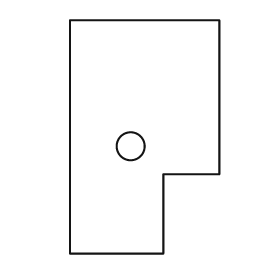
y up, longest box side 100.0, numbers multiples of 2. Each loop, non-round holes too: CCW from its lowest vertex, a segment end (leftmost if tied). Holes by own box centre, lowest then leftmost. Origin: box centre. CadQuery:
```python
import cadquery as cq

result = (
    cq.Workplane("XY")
    .moveTo(-32.0, -50.0)
    .lineTo(8.0, -50.0)
    .lineTo(8.0, -16.0)
    .lineTo(32.0, -16.0)
    .lineTo(32.0, 50.0)
    .lineTo(-32.0, 50.0)
    .close()
    .moveTo(-6.0, -4.0)
    .circle(6.0)
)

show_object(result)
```